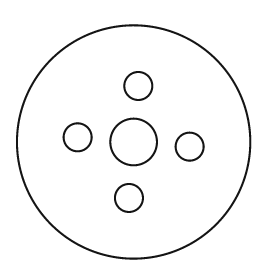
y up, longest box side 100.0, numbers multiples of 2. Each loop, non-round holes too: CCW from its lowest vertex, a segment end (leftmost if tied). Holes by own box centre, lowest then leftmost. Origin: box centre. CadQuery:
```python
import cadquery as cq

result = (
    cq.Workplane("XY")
    .moveTo(0.0, 0.0)
    .circle(50.0)
    .moveTo(-2.0, -24.0)
    .circle(6.0)
    .moveTo(24.0, -2.0)
    .circle(6.0)
    .moveTo(0.0, 0.0)
    .circle(10.0)
    .moveTo(-24.0, 2.0)
    .circle(6.0)
    .moveTo(2.0, 24.0)
    .circle(6.0)
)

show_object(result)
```